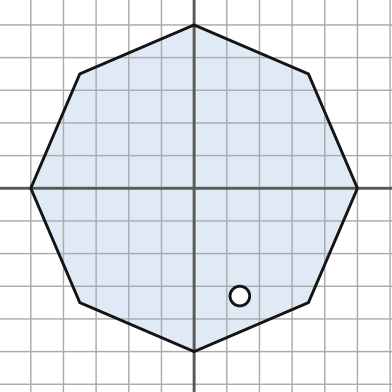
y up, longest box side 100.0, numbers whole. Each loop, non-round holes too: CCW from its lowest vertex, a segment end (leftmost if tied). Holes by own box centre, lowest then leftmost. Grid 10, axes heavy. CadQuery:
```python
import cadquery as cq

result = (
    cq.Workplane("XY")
    .moveTo(0.0, -50.0)
    .lineTo(35.0, -35.0)
    .lineTo(50.0, 0.0)
    .lineTo(35.0, 35.0)
    .lineTo(0.0, 50.0)
    .lineTo(-35.0, 35.0)
    .lineTo(-50.0, 0.0)
    .lineTo(-35.0, -35.0)
    .close()
    .moveTo(14.0, -33.0)
    .circle(3.0)
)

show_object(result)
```